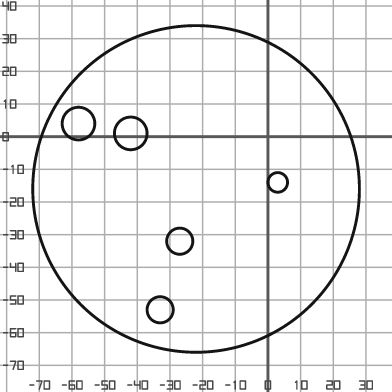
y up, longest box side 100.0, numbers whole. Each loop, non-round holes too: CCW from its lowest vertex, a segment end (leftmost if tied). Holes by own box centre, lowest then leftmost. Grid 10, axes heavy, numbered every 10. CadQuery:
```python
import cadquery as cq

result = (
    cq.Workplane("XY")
    .moveTo(-22.0, -16.0)
    .circle(50.0)
    .moveTo(-33.0, -53.0)
    .circle(4.0)
    .moveTo(-27.0, -32.0)
    .circle(4.0)
    .moveTo(3.0, -14.0)
    .circle(3.0)
    .moveTo(-42.0, 1.0)
    .circle(5.0)
    .moveTo(-58.0, 4.0)
    .circle(5.0)
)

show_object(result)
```